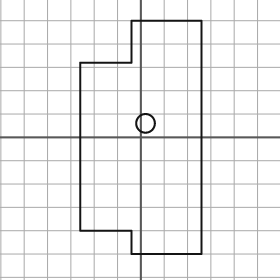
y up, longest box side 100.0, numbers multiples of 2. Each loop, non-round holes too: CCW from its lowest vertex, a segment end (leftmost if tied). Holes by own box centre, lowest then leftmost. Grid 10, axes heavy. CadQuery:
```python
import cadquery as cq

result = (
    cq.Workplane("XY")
    .moveTo(-4.0, -50.0)
    .lineTo(26.0, -50.0)
    .lineTo(26.0, 50.0)
    .lineTo(-4.0, 50.0)
    .lineTo(-4.0, 32.0)
    .lineTo(-26.0, 32.0)
    .lineTo(-26.0, -40.0)
    .lineTo(-4.0, -40.0)
    .close()
    .moveTo(2.0, 6.0)
    .circle(4.0)
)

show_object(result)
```